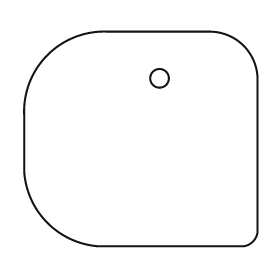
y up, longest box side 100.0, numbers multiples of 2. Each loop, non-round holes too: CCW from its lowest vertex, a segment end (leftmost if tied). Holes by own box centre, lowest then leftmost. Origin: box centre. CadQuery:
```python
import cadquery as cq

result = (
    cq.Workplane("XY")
    .moveTo(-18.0, -46.0)
    .lineTo(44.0, -46.0)
    .threePointArc((48.0, -44.0), (50.0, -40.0))
    .lineTo(50.0, 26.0)
    .threePointArc((44.0, 40.0), (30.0, 46.0))
    .lineTo(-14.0, 46.0)
    .threePointArc((-40.0, 36.0), (-50.0, 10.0))
    .lineTo(-50.0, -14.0)
    .threePointArc((-40.0, -36.0), (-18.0, -46.0))
    .close()
    .moveTo(8.0, 26.0)
    .circle(4.0)
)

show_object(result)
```